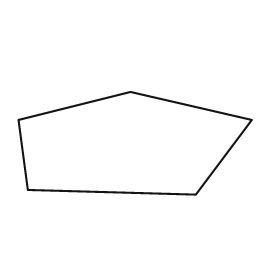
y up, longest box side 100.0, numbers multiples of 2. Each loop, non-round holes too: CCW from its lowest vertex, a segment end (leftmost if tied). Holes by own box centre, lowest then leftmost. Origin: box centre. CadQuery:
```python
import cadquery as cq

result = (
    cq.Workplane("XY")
    .moveTo(26.0, -22.0)
    .lineTo(50.0, 10.0)
    .lineTo(-2.0, 22.0)
    .lineTo(-50.0, 10.0)
    .lineTo(-46.0, -20.0)
    .close()
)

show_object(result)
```